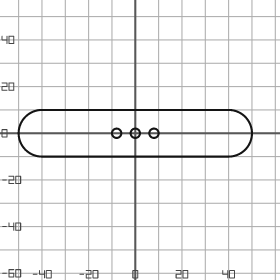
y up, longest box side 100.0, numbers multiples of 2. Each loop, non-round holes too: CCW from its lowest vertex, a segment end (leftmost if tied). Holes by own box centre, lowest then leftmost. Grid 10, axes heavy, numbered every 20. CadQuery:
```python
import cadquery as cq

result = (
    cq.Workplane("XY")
    .moveTo(-40.0, -10.0)
    .lineTo(40.0, -10.0)
    .threePointArc((50.0, 0.0), (40.0, 10.0))
    .lineTo(-40.0, 10.0)
    .threePointArc((-50.0, 0.0), (-40.0, -10.0))
    .close()
    .moveTo(-8.0, 0.0)
    .circle(2.0)
    .moveTo(0.0, 0.0)
    .circle(2.0)
    .moveTo(8.0, 0.0)
    .circle(2.0)
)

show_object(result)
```